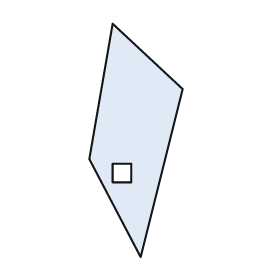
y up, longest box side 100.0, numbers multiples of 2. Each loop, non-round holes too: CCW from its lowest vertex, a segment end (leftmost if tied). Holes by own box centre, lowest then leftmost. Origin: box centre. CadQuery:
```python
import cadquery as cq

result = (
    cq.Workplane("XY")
    .moveTo(2.0, -50.0)
    .lineTo(20.0, 22.0)
    .lineTo(-10.0, 50.0)
    .lineTo(-20.0, -8.0)
    .close()
    .moveTo(-10.0, -18.0)
    .lineTo(-2.0, -18.0)
    .lineTo(-2.0, -10.0)
    .lineTo(-10.0, -10.0)
    .close()
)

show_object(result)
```